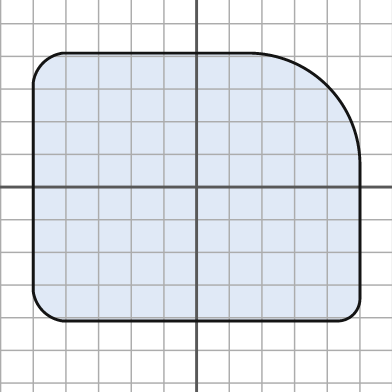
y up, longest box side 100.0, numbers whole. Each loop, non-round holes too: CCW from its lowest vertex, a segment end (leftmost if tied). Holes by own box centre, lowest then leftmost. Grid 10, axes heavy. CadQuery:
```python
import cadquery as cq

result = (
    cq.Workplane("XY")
    .moveTo(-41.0, -41.0)
    .lineTo(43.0, -41.0)
    .threePointArc((48.0, -39.0), (50.0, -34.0))
    .lineTo(50.0, 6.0)
    .threePointArc((40.0, 31.0), (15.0, 41.0))
    .lineTo(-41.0, 41.0)
    .threePointArc((-47.0, 38.0), (-50.0, 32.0))
    .lineTo(-50.0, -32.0)
    .threePointArc((-47.0, -38.0), (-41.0, -41.0))
    .close()
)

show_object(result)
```